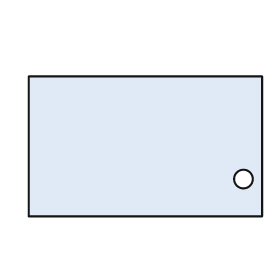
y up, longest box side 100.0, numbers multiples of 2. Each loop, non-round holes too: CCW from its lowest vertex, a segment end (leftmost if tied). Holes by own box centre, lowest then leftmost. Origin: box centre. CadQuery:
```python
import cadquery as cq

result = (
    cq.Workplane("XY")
    .moveTo(-50.0, -30.0)
    .lineTo(50.0, -30.0)
    .lineTo(50.0, 30.0)
    .lineTo(-50.0, 30.0)
    .close()
    .moveTo(42.0, -14.0)
    .circle(4.0)
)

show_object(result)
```